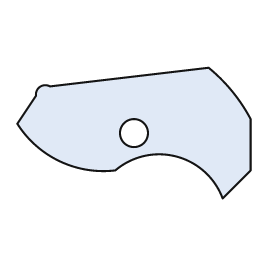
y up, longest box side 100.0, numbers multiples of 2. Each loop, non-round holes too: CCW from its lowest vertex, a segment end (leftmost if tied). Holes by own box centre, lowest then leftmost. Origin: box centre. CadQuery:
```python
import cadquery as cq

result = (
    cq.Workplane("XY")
    .moveTo(38.0, -28.0)
    .lineTo(50.0, -16.0)
    .lineTo(50.0, 6.0)
    .threePointArc((42.0, 18.0), (32.0, 28.0))
    .lineTo(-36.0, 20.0)
    .threePointArc((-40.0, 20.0), (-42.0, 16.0))
    .lineTo(-50.0, 4.0)
    .threePointArc((-32.0, -12.0), (-8.0, -16.0))
    .threePointArc((18.0, -10.0), (38.0, -28.0))
    .close()
    .moveTo(0.0, 0.0)
    .circle(6.0)
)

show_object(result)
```